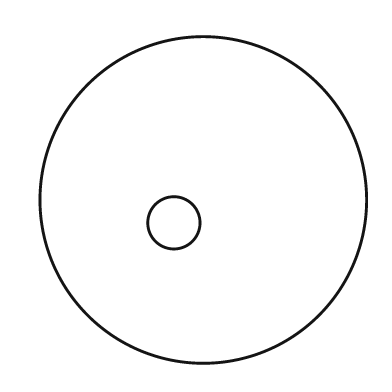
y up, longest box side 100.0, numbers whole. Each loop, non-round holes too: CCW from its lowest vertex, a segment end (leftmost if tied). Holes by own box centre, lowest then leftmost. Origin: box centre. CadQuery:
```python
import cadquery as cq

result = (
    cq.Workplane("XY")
    .moveTo(0.0, 0.0)
    .circle(50.0)
    .moveTo(-9.0, -7.0)
    .circle(8.0)
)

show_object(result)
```